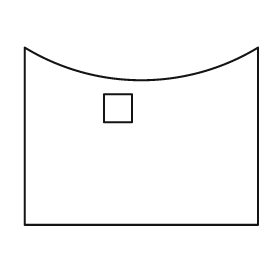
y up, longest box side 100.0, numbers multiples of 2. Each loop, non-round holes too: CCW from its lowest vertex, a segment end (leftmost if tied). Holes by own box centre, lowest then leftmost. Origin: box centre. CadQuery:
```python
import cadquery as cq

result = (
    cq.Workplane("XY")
    .moveTo(-50.0, -38.0)
    .lineTo(50.0, -38.0)
    .lineTo(50.0, 38.0)
    .threePointArc((0.0, 24.0), (-50.0, 38.0))
    .close()
    .moveTo(-16.0, 6.0)
    .lineTo(-4.0, 6.0)
    .lineTo(-4.0, 18.0)
    .lineTo(-16.0, 18.0)
    .close()
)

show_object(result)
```